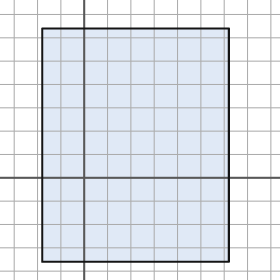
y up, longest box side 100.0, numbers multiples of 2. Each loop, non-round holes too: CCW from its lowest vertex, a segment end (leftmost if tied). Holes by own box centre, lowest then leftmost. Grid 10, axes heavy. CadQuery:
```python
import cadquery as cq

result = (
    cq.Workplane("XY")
    .moveTo(-18.0, -36.0)
    .lineTo(62.0, -36.0)
    .lineTo(62.0, 64.0)
    .lineTo(-18.0, 64.0)
    .close()
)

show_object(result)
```